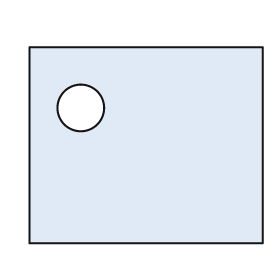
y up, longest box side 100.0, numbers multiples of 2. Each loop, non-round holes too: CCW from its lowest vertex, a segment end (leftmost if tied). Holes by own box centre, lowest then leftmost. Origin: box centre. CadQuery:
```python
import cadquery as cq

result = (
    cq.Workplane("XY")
    .moveTo(-50.0, -42.0)
    .lineTo(50.0, -42.0)
    .lineTo(50.0, 42.0)
    .lineTo(-50.0, 42.0)
    .close()
    .moveTo(-28.0, 16.0)
    .circle(10.0)
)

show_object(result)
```